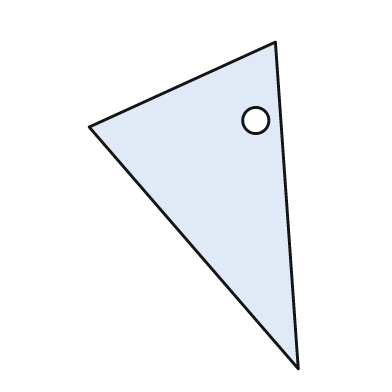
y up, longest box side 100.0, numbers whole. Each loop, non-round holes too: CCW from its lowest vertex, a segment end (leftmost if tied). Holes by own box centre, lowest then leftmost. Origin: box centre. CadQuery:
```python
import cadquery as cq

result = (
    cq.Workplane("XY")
    .moveTo(32.0, -50.0)
    .lineTo(25.0, 50.0)
    .lineTo(-32.0, 24.0)
    .close()
    .moveTo(19.0, 26.0)
    .circle(4.0)
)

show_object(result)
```